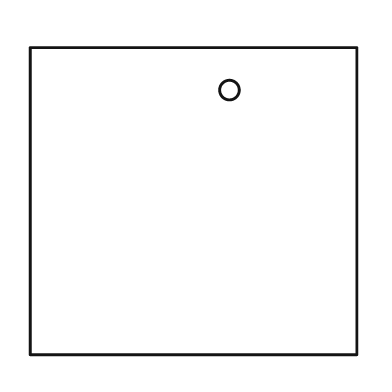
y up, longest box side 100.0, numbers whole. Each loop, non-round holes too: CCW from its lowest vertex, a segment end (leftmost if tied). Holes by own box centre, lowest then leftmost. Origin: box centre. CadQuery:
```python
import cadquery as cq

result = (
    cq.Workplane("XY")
    .moveTo(-50.0, -47.0)
    .lineTo(50.0, -47.0)
    .lineTo(50.0, 47.0)
    .lineTo(-50.0, 47.0)
    .close()
    .moveTo(11.0, 34.0)
    .circle(3.0)
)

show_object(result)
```